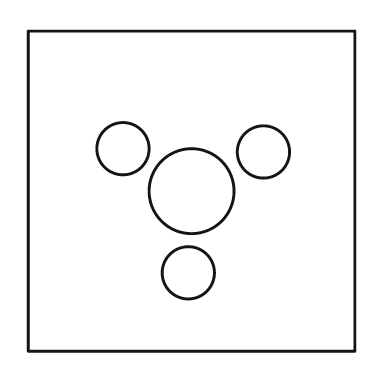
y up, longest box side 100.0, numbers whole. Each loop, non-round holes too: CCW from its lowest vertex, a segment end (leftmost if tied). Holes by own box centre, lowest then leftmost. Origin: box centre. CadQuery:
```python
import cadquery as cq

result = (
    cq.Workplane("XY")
    .moveTo(-50.0, -49.0)
    .lineTo(50.0, -49.0)
    .lineTo(50.0, 49.0)
    .lineTo(-50.0, 49.0)
    .close()
    .moveTo(-1.0, -25.0)
    .circle(8.0)
    .moveTo(0.0, 0.0)
    .circle(13.0)
    .moveTo(22.0, 12.0)
    .circle(8.0)
    .moveTo(-21.0, 13.0)
    .circle(8.0)
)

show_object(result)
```